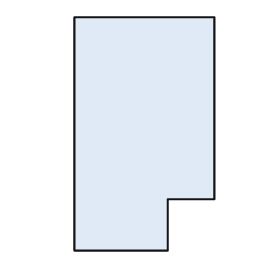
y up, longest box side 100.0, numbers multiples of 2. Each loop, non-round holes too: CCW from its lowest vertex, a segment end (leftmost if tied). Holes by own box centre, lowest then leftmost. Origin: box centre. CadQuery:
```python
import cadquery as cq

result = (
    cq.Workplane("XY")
    .moveTo(-30.0, -50.0)
    .lineTo(10.0, -50.0)
    .lineTo(10.0, -28.0)
    .lineTo(30.0, -28.0)
    .lineTo(30.0, 50.0)
    .lineTo(-30.0, 50.0)
    .close()
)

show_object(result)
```